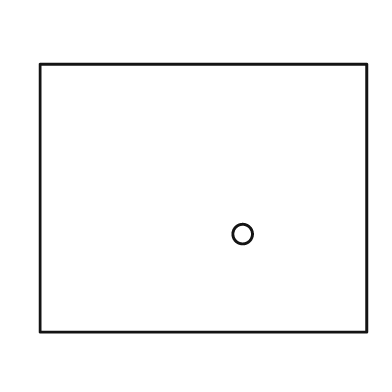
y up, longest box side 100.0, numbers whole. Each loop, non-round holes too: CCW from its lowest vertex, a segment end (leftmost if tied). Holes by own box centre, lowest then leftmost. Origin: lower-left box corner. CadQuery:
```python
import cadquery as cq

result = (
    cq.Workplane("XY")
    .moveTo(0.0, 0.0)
    .lineTo(100.0, 0.0)
    .lineTo(100.0, 82.0)
    .lineTo(0.0, 82.0)
    .close()
    .moveTo(62.0, 30.0)
    .circle(3.0)
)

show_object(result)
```